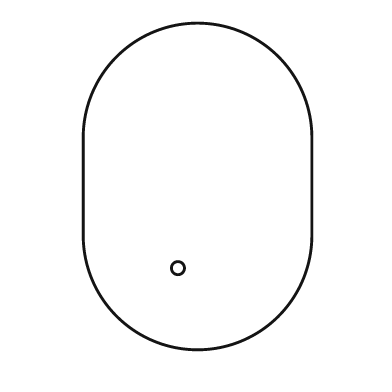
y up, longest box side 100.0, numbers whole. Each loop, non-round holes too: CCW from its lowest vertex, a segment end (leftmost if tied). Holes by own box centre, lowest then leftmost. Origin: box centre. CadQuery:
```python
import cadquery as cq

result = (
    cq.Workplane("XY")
    .moveTo(-35.0, -15.0)
    .threePointArc((0.0, -50.0), (35.0, -15.0))
    .lineTo(35.0, 15.0)
    .threePointArc((0.0, 50.0), (-35.0, 15.0))
    .close()
    .moveTo(-6.0, -25.0)
    .circle(2.0)
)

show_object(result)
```